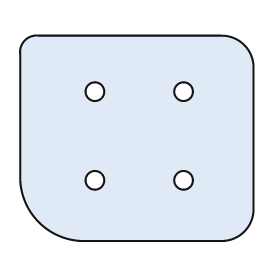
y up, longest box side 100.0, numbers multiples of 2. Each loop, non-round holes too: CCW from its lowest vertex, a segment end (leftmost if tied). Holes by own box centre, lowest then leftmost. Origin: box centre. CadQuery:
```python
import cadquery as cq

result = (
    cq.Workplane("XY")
    .moveTo(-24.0, -44.0)
    .lineTo(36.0, -44.0)
    .threePointArc((46.0, -40.0), (50.0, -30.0))
    .lineTo(50.0, 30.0)
    .threePointArc((46.0, 40.0), (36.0, 44.0))
    .lineTo(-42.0, 44.0)
    .threePointArc((-48.0, 42.0), (-50.0, 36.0))
    .lineTo(-50.0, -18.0)
    .threePointArc((-42.0, -36.0), (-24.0, -44.0))
    .close()
    .moveTo(-18.0, -18.0)
    .circle(4.0)
    .moveTo(20.0, -18.0)
    .circle(4.0)
    .moveTo(-18.0, 20.0)
    .circle(4.0)
    .moveTo(20.0, 20.0)
    .circle(4.0)
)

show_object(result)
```